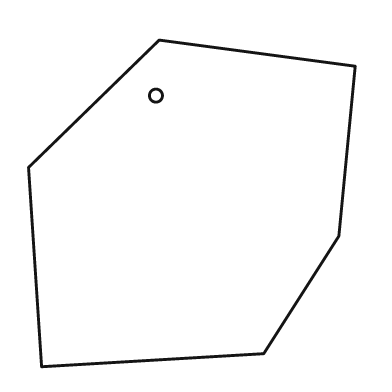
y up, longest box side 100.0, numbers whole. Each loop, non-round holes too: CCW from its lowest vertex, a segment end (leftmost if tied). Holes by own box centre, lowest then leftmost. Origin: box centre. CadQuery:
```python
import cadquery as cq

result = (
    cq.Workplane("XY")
    .moveTo(-46.0, -50.0)
    .lineTo(22.0, -46.0)
    .lineTo(45.0, -10.0)
    .lineTo(50.0, 42.0)
    .lineTo(-10.0, 50.0)
    .lineTo(-50.0, 11.0)
    .close()
    .moveTo(-11.0, 33.0)
    .circle(2.0)
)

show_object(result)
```